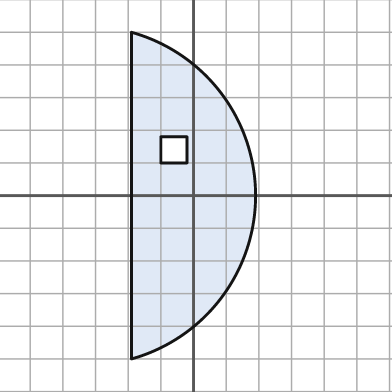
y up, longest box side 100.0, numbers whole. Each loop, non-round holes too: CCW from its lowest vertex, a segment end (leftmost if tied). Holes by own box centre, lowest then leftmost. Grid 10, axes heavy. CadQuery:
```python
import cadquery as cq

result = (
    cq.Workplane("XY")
    .moveTo(-19.0, -50.0)
    .threePointArc((19.0, 0.0), (-19.0, 50.0))
    .close()
    .moveTo(-10.0, 10.0)
    .lineTo(-2.0, 10.0)
    .lineTo(-2.0, 18.0)
    .lineTo(-10.0, 18.0)
    .close()
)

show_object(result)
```